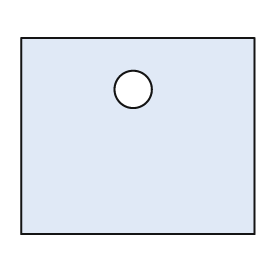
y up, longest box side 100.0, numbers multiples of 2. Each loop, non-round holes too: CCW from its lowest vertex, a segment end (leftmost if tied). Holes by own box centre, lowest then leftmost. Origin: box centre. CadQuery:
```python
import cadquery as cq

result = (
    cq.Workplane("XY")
    .moveTo(-50.0, -42.0)
    .lineTo(50.0, -42.0)
    .lineTo(50.0, 42.0)
    .lineTo(-50.0, 42.0)
    .close()
    .moveTo(-2.0, 20.0)
    .circle(8.0)
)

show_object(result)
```